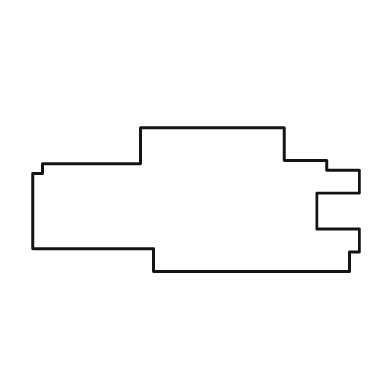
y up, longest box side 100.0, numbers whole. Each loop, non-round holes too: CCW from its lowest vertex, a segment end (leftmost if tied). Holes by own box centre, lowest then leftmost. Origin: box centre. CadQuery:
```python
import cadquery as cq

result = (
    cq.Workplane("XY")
    .moveTo(-13.0, -22.0)
    .lineTo(47.0, -22.0)
    .lineTo(47.0, -16.0)
    .lineTo(50.0, -16.0)
    .lineTo(50.0, -9.0)
    .lineTo(37.0, -9.0)
    .lineTo(37.0, 2.0)
    .lineTo(50.0, 2.0)
    .lineTo(50.0, 9.0)
    .lineTo(40.0, 9.0)
    .lineTo(40.0, 12.0)
    .lineTo(27.0, 12.0)
    .lineTo(27.0, 22.0)
    .lineTo(-17.0, 22.0)
    .lineTo(-17.0, 11.0)
    .lineTo(-47.0, 11.0)
    .lineTo(-47.0, 8.0)
    .lineTo(-50.0, 8.0)
    .lineTo(-50.0, -15.0)
    .lineTo(-13.0, -15.0)
    .close()
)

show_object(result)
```